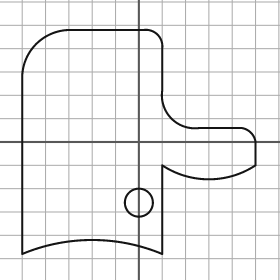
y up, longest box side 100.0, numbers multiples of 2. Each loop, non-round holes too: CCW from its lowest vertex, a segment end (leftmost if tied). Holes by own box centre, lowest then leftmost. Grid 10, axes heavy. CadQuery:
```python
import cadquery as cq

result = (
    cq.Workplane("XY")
    .moveTo(-50.0, -48.0)
    .threePointArc((-20.0, -42.0), (10.0, -48.0))
    .lineTo(10.0, -10.0)
    .threePointArc((30.0, -16.0), (50.0, -10.0))
    .lineTo(50.0, 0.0)
    .threePointArc((48.0, 4.0), (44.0, 6.0))
    .lineTo(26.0, 6.0)
    .threePointArc((14.0, 10.0), (10.0, 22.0))
    .lineTo(10.0, 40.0)
    .threePointArc((8.0, 46.0), (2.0, 48.0))
    .lineTo(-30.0, 48.0)
    .threePointArc((-44.0, 42.0), (-50.0, 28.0))
    .close()
    .moveTo(0.0, -26.0)
    .circle(6.0)
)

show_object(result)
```